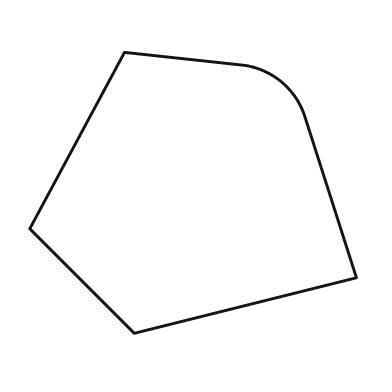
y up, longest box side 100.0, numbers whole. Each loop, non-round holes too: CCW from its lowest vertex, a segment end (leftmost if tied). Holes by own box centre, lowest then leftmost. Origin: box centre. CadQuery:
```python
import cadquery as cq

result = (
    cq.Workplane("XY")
    .moveTo(-18.0, -43.0)
    .lineTo(50.0, -26.0)
    .lineTo(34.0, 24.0)
    .threePointArc((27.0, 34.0), (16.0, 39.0))
    .lineTo(-21.0, 43.0)
    .lineTo(-50.0, -11.0)
    .close()
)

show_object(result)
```